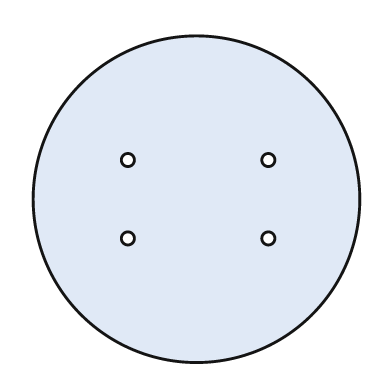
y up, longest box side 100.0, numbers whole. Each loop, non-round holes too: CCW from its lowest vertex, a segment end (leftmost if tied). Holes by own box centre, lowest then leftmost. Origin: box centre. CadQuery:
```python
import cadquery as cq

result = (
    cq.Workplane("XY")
    .moveTo(0.0, 0.0)
    .circle(50.0)
    .moveTo(-21.0, -12.0)
    .circle(2.0)
    .moveTo(22.0, -12.0)
    .circle(2.0)
    .moveTo(-21.0, 12.0)
    .circle(2.0)
    .moveTo(22.0, 12.0)
    .circle(2.0)
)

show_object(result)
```